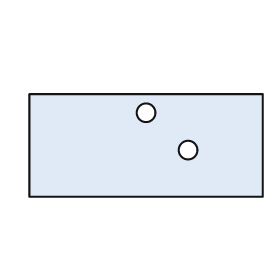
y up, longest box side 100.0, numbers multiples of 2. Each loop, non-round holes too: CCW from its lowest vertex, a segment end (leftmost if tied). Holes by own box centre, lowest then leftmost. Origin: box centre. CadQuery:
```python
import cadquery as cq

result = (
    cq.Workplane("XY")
    .moveTo(-50.0, -22.0)
    .lineTo(50.0, -22.0)
    .lineTo(50.0, 22.0)
    .lineTo(-50.0, 22.0)
    .close()
    .moveTo(18.0, -2.0)
    .circle(4.0)
    .moveTo(0.0, 14.0)
    .circle(4.0)
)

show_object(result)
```